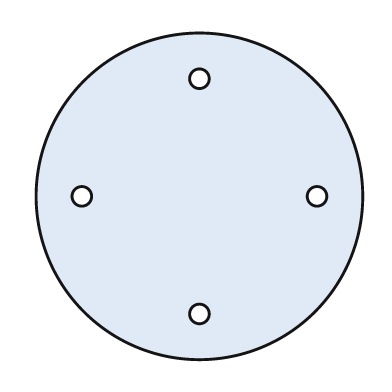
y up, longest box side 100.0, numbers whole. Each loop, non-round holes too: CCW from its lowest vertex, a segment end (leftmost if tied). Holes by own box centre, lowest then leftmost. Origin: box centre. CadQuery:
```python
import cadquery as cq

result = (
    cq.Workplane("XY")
    .moveTo(0.0, 0.0)
    .circle(50.0)
    .moveTo(0.0, -36.0)
    .circle(3.0)
    .moveTo(-36.0, 0.0)
    .circle(3.0)
    .moveTo(36.0, 0.0)
    .circle(3.0)
    .moveTo(0.0, 36.0)
    .circle(3.0)
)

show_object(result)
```